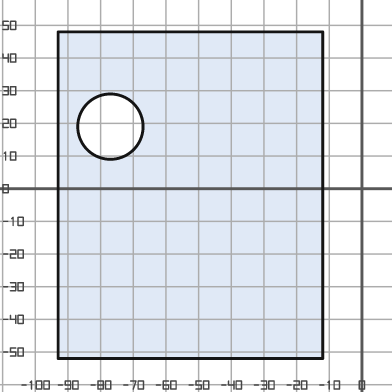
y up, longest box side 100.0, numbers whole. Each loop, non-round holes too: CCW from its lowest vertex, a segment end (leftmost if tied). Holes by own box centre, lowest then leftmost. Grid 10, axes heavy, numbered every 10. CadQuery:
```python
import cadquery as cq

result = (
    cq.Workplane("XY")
    .moveTo(-93.0, -52.0)
    .lineTo(-12.0, -52.0)
    .lineTo(-12.0, 48.0)
    .lineTo(-93.0, 48.0)
    .close()
    .moveTo(-77.0, 19.0)
    .circle(10.0)
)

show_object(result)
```